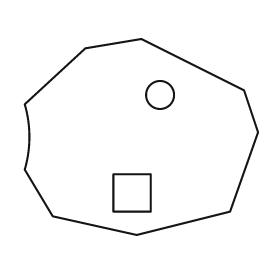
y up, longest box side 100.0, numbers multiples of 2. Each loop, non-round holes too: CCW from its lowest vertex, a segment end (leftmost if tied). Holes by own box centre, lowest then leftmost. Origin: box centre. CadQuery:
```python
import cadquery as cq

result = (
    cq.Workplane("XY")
    .moveTo(-2.0, -42.0)
    .lineTo(38.0, -32.0)
    .lineTo(50.0, 2.0)
    .lineTo(44.0, 20.0)
    .lineTo(0.0, 42.0)
    .lineTo(-24.0, 38.0)
    .lineTo(-50.0, 14.0)
    .threePointArc((-48.0, 0.0), (-50.0, -14.0))
    .lineTo(-38.0, -34.0)
    .close()
    .moveTo(-12.0, -32.0)
    .lineTo(4.0, -32.0)
    .lineTo(4.0, -16.0)
    .lineTo(-12.0, -16.0)
    .close()
    .moveTo(8.0, 18.0)
    .circle(6.0)
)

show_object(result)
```